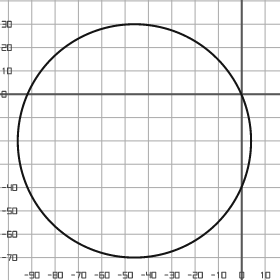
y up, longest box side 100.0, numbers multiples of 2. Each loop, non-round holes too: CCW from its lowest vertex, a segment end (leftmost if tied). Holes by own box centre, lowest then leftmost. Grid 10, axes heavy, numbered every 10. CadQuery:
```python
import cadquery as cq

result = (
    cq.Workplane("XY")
    .moveTo(-46.0, -20.0)
    .circle(50.0)
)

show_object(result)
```